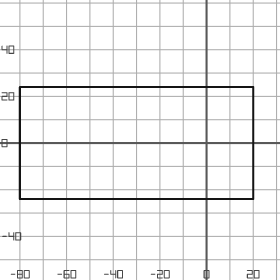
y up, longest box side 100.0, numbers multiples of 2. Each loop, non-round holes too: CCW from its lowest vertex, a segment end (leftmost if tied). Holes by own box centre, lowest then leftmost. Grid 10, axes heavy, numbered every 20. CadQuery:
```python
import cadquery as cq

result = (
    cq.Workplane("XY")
    .moveTo(-80.0, -24.0)
    .lineTo(20.0, -24.0)
    .lineTo(20.0, 24.0)
    .lineTo(-80.0, 24.0)
    .close()
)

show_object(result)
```